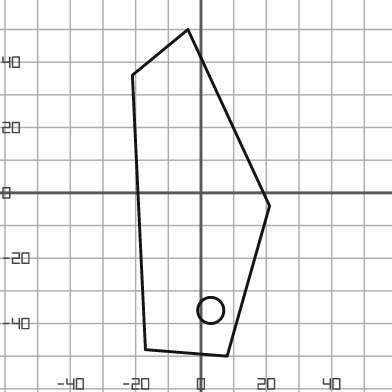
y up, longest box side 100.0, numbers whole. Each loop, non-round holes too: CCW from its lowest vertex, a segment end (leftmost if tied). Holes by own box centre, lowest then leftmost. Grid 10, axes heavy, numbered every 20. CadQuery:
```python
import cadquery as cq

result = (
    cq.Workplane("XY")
    .moveTo(8.0, -50.0)
    .lineTo(21.0, -4.0)
    .lineTo(-4.0, 50.0)
    .lineTo(-21.0, 36.0)
    .lineTo(-17.0, -48.0)
    .close()
    .moveTo(3.0, -36.0)
    .circle(4.0)
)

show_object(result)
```